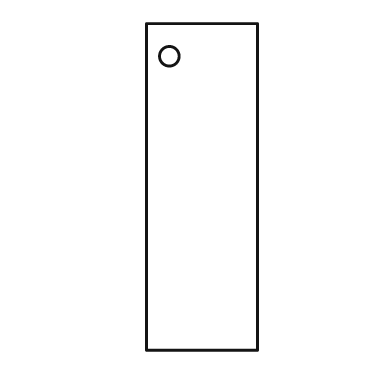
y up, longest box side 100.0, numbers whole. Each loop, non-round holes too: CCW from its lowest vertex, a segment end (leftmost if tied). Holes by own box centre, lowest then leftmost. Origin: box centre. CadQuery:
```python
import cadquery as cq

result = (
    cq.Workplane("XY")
    .moveTo(-17.0, -50.0)
    .lineTo(17.0, -50.0)
    .lineTo(17.0, 50.0)
    .lineTo(-17.0, 50.0)
    .close()
    .moveTo(-10.0, 40.0)
    .circle(3.0)
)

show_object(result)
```